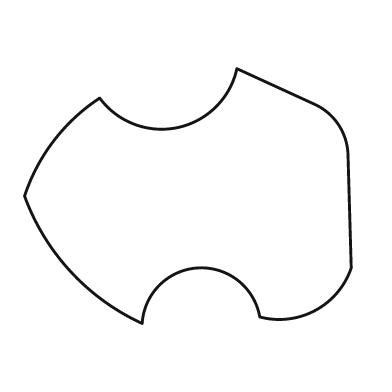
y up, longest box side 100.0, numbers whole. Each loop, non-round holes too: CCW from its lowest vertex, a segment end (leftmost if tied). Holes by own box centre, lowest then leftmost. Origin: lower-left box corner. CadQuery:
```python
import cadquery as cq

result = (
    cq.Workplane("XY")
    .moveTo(36.0, 0.0)
    .threePointArc((53.0, 17.0), (72.0, 2.0))
    .threePointArc((89.0, 4.0), (100.0, 17.0))
    .lineTo(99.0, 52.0)
    .threePointArc((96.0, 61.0), (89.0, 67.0))
    .lineTo(65.0, 78.0)
    .threePointArc((47.0, 60.0), (23.0, 69.0))
    .threePointArc((9.0, 56.0), (0.0, 39.0))
    .threePointArc((14.0, 16.0), (36.0, 0.0))
    .close()
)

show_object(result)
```